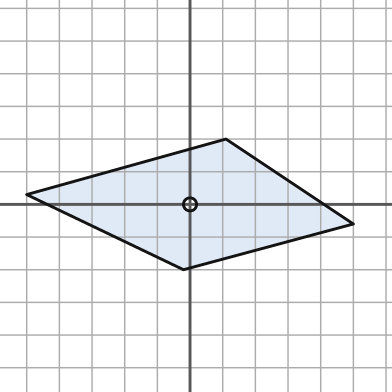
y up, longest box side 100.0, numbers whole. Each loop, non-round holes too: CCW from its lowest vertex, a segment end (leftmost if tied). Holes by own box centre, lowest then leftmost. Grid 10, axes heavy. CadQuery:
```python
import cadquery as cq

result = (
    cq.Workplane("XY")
    .moveTo(-2.0, -20.0)
    .lineTo(50.0, -6.0)
    .lineTo(11.0, 20.0)
    .lineTo(-50.0, 3.0)
    .close()
    .moveTo(0.0, 0.0)
    .circle(2.0)
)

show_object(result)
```